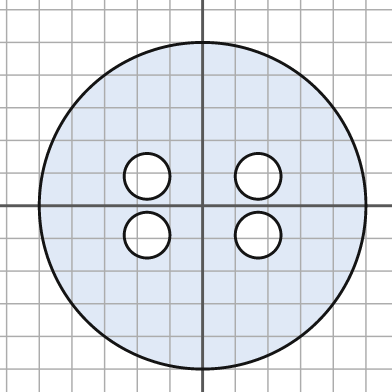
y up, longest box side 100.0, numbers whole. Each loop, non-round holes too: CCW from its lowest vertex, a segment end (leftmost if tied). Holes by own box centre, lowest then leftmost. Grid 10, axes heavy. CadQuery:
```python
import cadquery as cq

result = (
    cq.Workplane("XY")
    .moveTo(0.0, 0.0)
    .circle(50.0)
    .moveTo(-17.0, -9.0)
    .circle(7.0)
    .moveTo(17.0, -9.0)
    .circle(7.0)
    .moveTo(-17.0, 9.0)
    .circle(7.0)
    .moveTo(17.0, 9.0)
    .circle(7.0)
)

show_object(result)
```